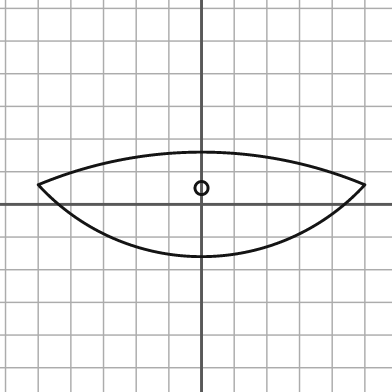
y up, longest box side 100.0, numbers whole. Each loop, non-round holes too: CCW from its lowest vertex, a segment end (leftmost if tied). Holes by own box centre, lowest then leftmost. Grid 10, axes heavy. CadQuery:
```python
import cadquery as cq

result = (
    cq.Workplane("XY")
    .moveTo(-50.0, 6.0)
    .threePointArc((0.0, -16.0), (50.0, 6.0))
    .threePointArc((0.0, 16.0), (-50.0, 6.0))
    .close()
    .moveTo(0.0, 5.0)
    .circle(2.0)
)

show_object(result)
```